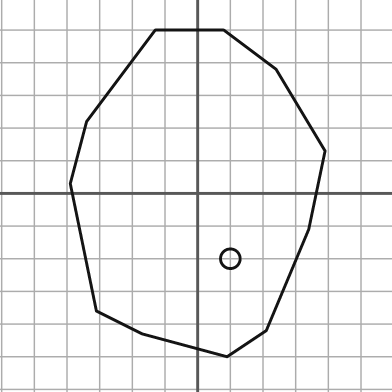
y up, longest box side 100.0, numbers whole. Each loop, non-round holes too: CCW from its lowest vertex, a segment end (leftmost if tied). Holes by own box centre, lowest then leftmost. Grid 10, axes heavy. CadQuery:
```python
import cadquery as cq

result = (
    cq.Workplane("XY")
    .moveTo(9.0, -50.0)
    .lineTo(21.0, -42.0)
    .lineTo(34.0, -11.0)
    .lineTo(39.0, 13.0)
    .lineTo(24.0, 38.0)
    .lineTo(8.0, 50.0)
    .lineTo(-13.0, 50.0)
    .lineTo(-34.0, 22.0)
    .lineTo(-39.0, 3.0)
    .lineTo(-31.0, -36.0)
    .lineTo(-17.0, -43.0)
    .close()
    .moveTo(10.0, -20.0)
    .circle(3.0)
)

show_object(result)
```